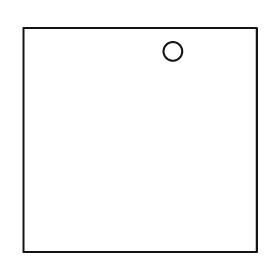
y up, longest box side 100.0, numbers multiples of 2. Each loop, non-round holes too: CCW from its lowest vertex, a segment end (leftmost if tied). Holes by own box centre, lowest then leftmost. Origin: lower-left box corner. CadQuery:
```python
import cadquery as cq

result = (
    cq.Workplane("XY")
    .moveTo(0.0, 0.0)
    .lineTo(100.0, 0.0)
    .lineTo(100.0, 96.0)
    .lineTo(0.0, 96.0)
    .close()
    .moveTo(64.0, 86.0)
    .circle(4.0)
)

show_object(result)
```